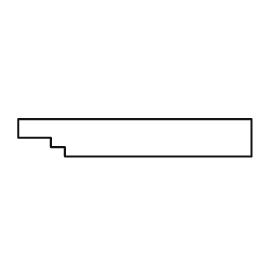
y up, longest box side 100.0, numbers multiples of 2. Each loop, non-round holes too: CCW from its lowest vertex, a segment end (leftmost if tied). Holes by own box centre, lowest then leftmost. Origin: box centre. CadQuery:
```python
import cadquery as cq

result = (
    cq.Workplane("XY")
    .moveTo(-30.0, -8.0)
    .lineTo(50.0, -8.0)
    .lineTo(50.0, 8.0)
    .lineTo(-50.0, 8.0)
    .lineTo(-50.0, 0.0)
    .lineTo(-36.0, 0.0)
    .lineTo(-36.0, -4.0)
    .lineTo(-30.0, -4.0)
    .close()
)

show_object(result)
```